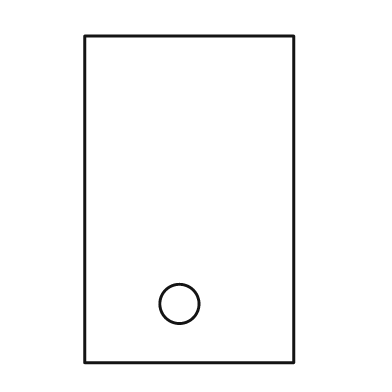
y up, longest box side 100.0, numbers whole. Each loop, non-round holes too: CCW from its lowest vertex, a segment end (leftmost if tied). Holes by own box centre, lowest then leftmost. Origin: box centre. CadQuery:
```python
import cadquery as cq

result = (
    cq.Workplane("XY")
    .moveTo(-32.0, -50.0)
    .lineTo(32.0, -50.0)
    .lineTo(32.0, 50.0)
    .lineTo(-32.0, 50.0)
    .close()
    .moveTo(-3.0, -32.0)
    .circle(6.0)
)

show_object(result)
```